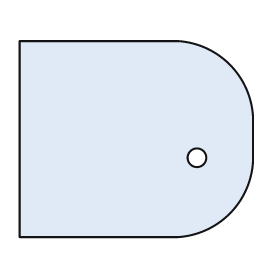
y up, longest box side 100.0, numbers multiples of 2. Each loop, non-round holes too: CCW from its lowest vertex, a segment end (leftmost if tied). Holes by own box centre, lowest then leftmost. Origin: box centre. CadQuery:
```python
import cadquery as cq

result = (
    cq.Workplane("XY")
    .moveTo(-50.0, -42.0)
    .lineTo(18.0, -42.0)
    .threePointArc((40.0, -32.0), (50.0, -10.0))
    .lineTo(50.0, 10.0)
    .threePointArc((40.0, 32.0), (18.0, 42.0))
    .lineTo(-50.0, 42.0)
    .close()
    .moveTo(26.0, -8.0)
    .circle(4.0)
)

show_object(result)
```